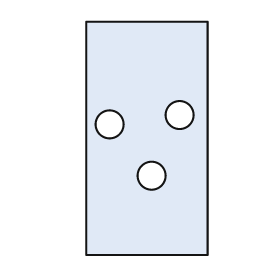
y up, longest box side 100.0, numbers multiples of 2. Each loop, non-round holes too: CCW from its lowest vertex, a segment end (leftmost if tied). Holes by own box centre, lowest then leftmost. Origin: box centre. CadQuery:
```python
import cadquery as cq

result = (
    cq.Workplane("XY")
    .moveTo(-26.0, -50.0)
    .lineTo(26.0, -50.0)
    .lineTo(26.0, 50.0)
    .lineTo(-26.0, 50.0)
    .close()
    .moveTo(2.0, -16.0)
    .circle(6.0)
    .moveTo(-16.0, 6.0)
    .circle(6.0)
    .moveTo(14.0, 10.0)
    .circle(6.0)
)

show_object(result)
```